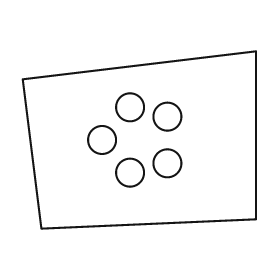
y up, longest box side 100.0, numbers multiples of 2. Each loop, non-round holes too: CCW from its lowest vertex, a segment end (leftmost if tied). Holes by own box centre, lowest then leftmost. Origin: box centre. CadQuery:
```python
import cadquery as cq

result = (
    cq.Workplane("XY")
    .moveTo(-42.0, -38.0)
    .lineTo(50.0, -34.0)
    .lineTo(50.0, 38.0)
    .lineTo(-50.0, 26.0)
    .close()
    .moveTo(-4.0, -14.0)
    .circle(6.0)
    .moveTo(12.0, -10.0)
    .circle(6.0)
    .moveTo(-16.0, 0.0)
    .circle(6.0)
    .moveTo(12.0, 10.0)
    .circle(6.0)
    .moveTo(-4.0, 14.0)
    .circle(6.0)
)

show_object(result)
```